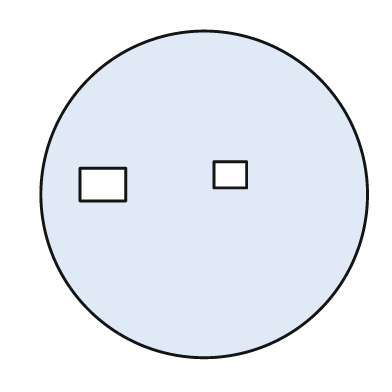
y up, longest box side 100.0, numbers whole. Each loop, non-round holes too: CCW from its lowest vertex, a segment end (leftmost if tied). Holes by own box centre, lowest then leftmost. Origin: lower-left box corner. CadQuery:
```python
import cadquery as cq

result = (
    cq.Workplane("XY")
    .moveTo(50.0, 50.0)
    .circle(50.0)
    .moveTo(12.0, 48.0)
    .lineTo(26.0, 48.0)
    .lineTo(26.0, 58.0)
    .lineTo(12.0, 58.0)
    .close()
    .moveTo(53.0, 52.0)
    .lineTo(63.0, 52.0)
    .lineTo(63.0, 60.0)
    .lineTo(53.0, 60.0)
    .close()
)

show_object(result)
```